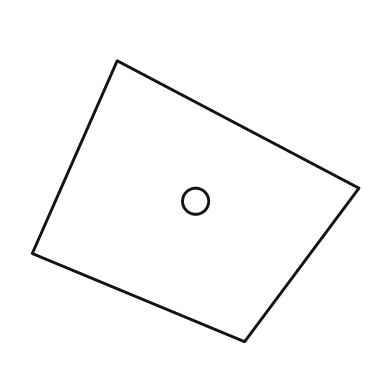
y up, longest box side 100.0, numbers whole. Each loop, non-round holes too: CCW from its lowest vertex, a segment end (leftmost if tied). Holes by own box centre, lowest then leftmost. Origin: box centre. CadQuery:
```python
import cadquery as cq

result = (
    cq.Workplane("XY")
    .moveTo(15.0, -43.0)
    .lineTo(50.0, 4.0)
    .lineTo(-24.0, 43.0)
    .lineTo(-50.0, -16.0)
    .close()
    .moveTo(0.0, 0.0)
    .circle(4.0)
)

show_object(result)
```